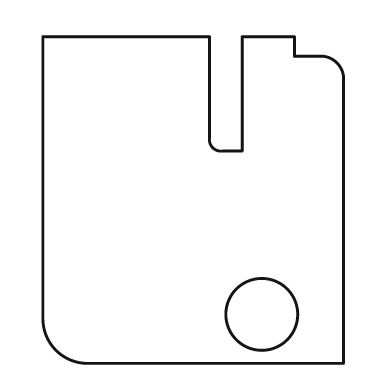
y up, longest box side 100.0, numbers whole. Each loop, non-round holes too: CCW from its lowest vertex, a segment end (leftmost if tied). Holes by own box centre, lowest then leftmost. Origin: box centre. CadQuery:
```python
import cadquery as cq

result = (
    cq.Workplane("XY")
    .moveTo(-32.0, -50.0)
    .lineTo(46.0, -50.0)
    .lineTo(46.0, 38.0)
    .threePointArc((44.0, 42.0), (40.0, 44.0))
    .lineTo(31.0, 44.0)
    .lineTo(31.0, 50.0)
    .lineTo(15.0, 50.0)
    .lineTo(15.0, 15.0)
    .lineTo(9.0, 15.0)
    .threePointArc((6.0, 16.0), (5.0, 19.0))
    .lineTo(5.0, 50.0)
    .lineTo(-46.0, 50.0)
    .lineTo(-46.0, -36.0)
    .threePointArc((-42.0, -46.0), (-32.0, -50.0))
    .close()
    .moveTo(21.0, -35.0)
    .circle(11.0)
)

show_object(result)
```